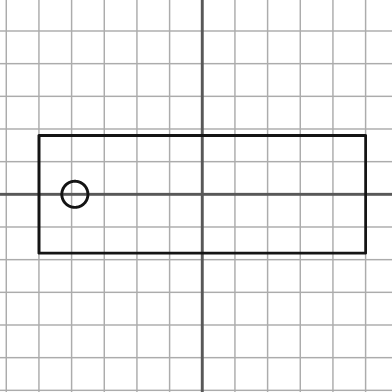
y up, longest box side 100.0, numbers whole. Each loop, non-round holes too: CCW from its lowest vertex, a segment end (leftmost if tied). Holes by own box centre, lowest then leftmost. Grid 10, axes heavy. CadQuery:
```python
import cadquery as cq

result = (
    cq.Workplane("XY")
    .moveTo(-50.0, -18.0)
    .lineTo(50.0, -18.0)
    .lineTo(50.0, 18.0)
    .lineTo(-50.0, 18.0)
    .close()
    .moveTo(-39.0, 0.0)
    .circle(4.0)
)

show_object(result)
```